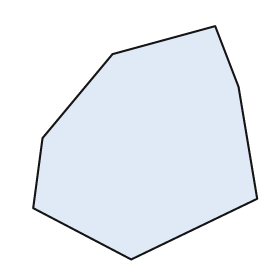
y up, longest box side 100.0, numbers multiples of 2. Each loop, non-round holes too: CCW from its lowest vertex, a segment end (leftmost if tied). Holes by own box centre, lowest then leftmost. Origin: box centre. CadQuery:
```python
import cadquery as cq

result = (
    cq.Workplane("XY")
    .moveTo(-6.0, -50.0)
    .lineTo(48.0, -24.0)
    .lineTo(40.0, 24.0)
    .lineTo(30.0, 50.0)
    .lineTo(-14.0, 38.0)
    .lineTo(-44.0, 2.0)
    .lineTo(-48.0, -28.0)
    .close()
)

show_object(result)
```